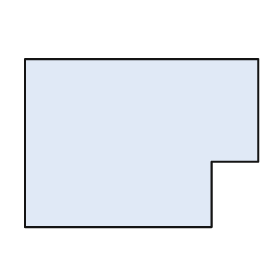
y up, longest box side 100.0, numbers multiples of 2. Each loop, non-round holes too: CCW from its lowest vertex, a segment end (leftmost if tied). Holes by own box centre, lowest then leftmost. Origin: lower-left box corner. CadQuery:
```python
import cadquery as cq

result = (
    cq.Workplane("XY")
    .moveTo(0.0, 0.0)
    .lineTo(80.0, 0.0)
    .lineTo(80.0, 28.0)
    .lineTo(100.0, 28.0)
    .lineTo(100.0, 72.0)
    .lineTo(0.0, 72.0)
    .close()
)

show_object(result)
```